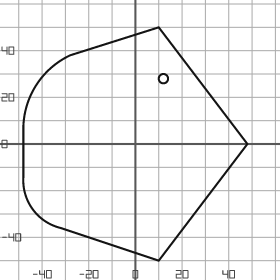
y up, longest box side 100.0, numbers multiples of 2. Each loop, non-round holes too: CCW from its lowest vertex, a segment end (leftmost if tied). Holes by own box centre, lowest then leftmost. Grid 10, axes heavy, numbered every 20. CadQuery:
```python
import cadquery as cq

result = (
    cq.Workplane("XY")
    .moveTo(10.0, -50.0)
    .lineTo(48.0, 0.0)
    .lineTo(10.0, 50.0)
    .lineTo(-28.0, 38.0)
    .threePointArc((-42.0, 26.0), (-48.0, 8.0))
    .lineTo(-48.0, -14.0)
    .threePointArc((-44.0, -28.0), (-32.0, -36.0))
    .close()
    .moveTo(12.0, 28.0)
    .circle(2.0)
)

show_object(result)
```